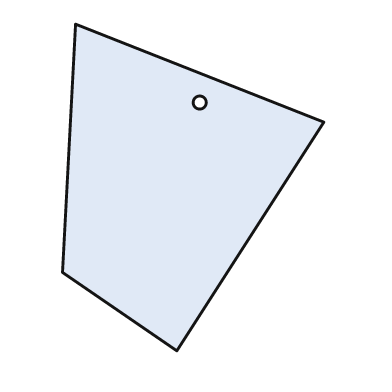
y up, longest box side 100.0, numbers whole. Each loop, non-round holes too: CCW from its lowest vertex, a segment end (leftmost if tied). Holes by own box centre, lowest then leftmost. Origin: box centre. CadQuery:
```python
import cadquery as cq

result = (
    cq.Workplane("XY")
    .moveTo(-5.0, -50.0)
    .lineTo(40.0, 20.0)
    .lineTo(-36.0, 50.0)
    .lineTo(-40.0, -26.0)
    .close()
    .moveTo(2.0, 26.0)
    .circle(2.0)
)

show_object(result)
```